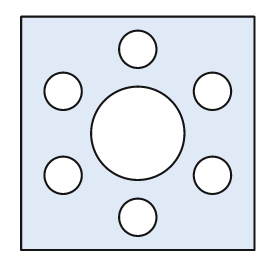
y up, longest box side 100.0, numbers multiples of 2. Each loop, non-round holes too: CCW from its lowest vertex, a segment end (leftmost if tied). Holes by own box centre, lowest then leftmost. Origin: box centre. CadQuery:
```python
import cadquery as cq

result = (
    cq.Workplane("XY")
    .moveTo(-50.0, -50.0)
    .lineTo(50.0, -50.0)
    .lineTo(50.0, 50.0)
    .lineTo(-50.0, 50.0)
    .close()
    .moveTo(0.0, -36.0)
    .circle(8.0)
    .moveTo(-32.0, -18.0)
    .circle(8.0)
    .moveTo(32.0, -18.0)
    .circle(8.0)
    .moveTo(0.0, 0.0)
    .circle(20.0)
    .moveTo(-32.0, 18.0)
    .circle(8.0)
    .moveTo(32.0, 18.0)
    .circle(8.0)
    .moveTo(0.0, 36.0)
    .circle(8.0)
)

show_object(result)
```